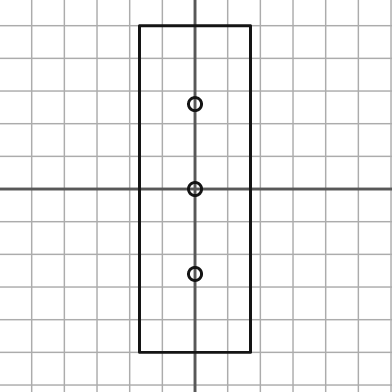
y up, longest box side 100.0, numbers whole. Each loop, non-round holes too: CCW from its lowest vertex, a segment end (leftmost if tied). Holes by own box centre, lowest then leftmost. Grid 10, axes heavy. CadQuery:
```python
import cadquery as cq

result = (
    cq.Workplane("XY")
    .moveTo(-17.0, -50.0)
    .lineTo(17.0, -50.0)
    .lineTo(17.0, 50.0)
    .lineTo(-17.0, 50.0)
    .close()
    .moveTo(0.0, -26.0)
    .circle(2.0)
    .moveTo(0.0, 0.0)
    .circle(2.0)
    .moveTo(0.0, 26.0)
    .circle(2.0)
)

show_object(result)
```